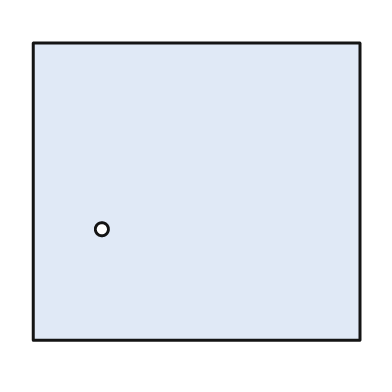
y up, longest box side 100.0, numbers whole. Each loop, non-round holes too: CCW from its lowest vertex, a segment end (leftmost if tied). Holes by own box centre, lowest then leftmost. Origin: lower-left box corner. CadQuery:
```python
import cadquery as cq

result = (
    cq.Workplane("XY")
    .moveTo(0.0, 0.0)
    .lineTo(100.0, 0.0)
    .lineTo(100.0, 91.0)
    .lineTo(0.0, 91.0)
    .close()
    .moveTo(21.0, 34.0)
    .circle(2.0)
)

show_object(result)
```